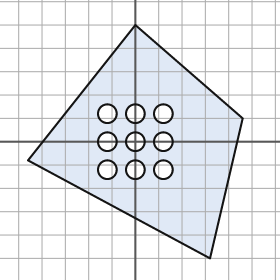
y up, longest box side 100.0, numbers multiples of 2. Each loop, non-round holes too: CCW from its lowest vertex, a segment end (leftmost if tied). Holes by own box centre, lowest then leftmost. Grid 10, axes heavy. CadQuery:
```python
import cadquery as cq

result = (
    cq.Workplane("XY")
    .moveTo(32.0, -50.0)
    .lineTo(46.0, 10.0)
    .lineTo(0.0, 50.0)
    .lineTo(-46.0, -8.0)
    .close()
    .moveTo(-12.0, -12.0)
    .circle(4.0)
    .moveTo(0.0, -12.0)
    .circle(4.0)
    .moveTo(12.0, -12.0)
    .circle(4.0)
    .moveTo(-12.0, 0.0)
    .circle(4.0)
    .moveTo(0.0, 0.0)
    .circle(4.0)
    .moveTo(12.0, 0.0)
    .circle(4.0)
    .moveTo(-12.0, 12.0)
    .circle(4.0)
    .moveTo(0.0, 12.0)
    .circle(4.0)
    .moveTo(12.0, 12.0)
    .circle(4.0)
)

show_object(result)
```